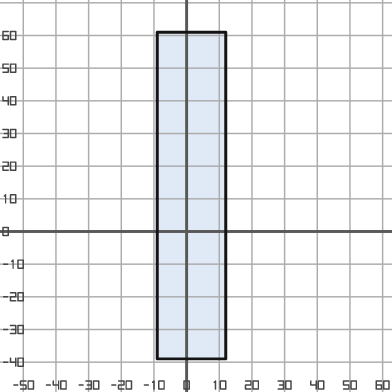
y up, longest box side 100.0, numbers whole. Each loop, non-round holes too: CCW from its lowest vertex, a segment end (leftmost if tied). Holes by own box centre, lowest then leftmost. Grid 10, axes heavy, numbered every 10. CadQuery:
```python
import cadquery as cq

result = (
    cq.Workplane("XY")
    .moveTo(-9.0, -39.0)
    .lineTo(12.0, -39.0)
    .lineTo(12.0, 61.0)
    .lineTo(-9.0, 61.0)
    .close()
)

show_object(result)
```